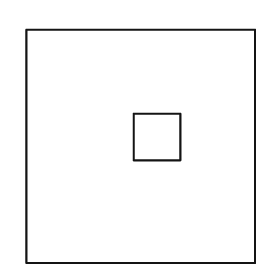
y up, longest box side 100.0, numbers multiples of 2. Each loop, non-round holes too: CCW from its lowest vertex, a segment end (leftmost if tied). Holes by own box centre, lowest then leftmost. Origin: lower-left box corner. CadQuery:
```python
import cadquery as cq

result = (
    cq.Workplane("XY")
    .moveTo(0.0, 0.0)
    .lineTo(98.0, 0.0)
    .lineTo(98.0, 100.0)
    .lineTo(0.0, 100.0)
    .close()
    .moveTo(46.0, 44.0)
    .lineTo(66.0, 44.0)
    .lineTo(66.0, 64.0)
    .lineTo(46.0, 64.0)
    .close()
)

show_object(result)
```